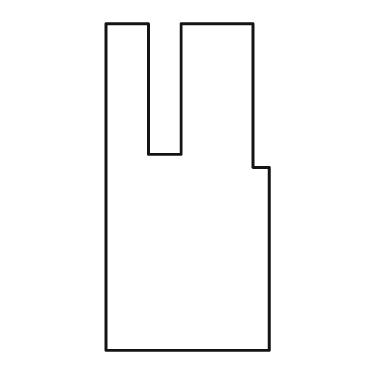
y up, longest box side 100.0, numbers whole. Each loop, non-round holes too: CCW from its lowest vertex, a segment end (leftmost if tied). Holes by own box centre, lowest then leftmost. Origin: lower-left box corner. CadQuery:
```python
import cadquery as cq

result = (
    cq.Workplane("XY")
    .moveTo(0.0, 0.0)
    .lineTo(50.0, 0.0)
    .lineTo(50.0, 56.0)
    .lineTo(45.0, 56.0)
    .lineTo(45.0, 100.0)
    .lineTo(23.0, 100.0)
    .lineTo(23.0, 60.0)
    .lineTo(13.0, 60.0)
    .lineTo(13.0, 100.0)
    .lineTo(0.0, 100.0)
    .close()
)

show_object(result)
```